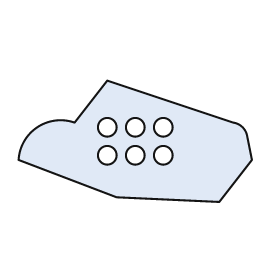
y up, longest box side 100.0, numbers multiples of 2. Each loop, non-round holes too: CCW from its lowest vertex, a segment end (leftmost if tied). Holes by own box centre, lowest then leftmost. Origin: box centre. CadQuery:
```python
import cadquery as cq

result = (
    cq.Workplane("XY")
    .moveTo(36.0, -26.0)
    .lineTo(50.0, -8.0)
    .lineTo(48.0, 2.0)
    .threePointArc((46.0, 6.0), (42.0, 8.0))
    .lineTo(-12.0, 26.0)
    .lineTo(-26.0, 8.0)
    .threePointArc((-42.0, 6.0), (-50.0, -8.0))
    .lineTo(-8.0, -24.0)
    .close()
    .moveTo(-12.0, -6.0)
    .circle(4.0)
    .moveTo(0.0, -6.0)
    .circle(4.0)
    .moveTo(12.0, -6.0)
    .circle(4.0)
    .moveTo(-12.0, 6.0)
    .circle(4.0)
    .moveTo(0.0, 6.0)
    .circle(4.0)
    .moveTo(12.0, 6.0)
    .circle(4.0)
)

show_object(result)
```